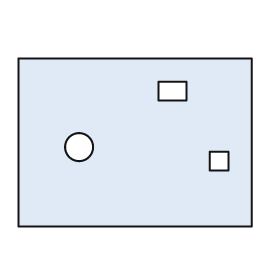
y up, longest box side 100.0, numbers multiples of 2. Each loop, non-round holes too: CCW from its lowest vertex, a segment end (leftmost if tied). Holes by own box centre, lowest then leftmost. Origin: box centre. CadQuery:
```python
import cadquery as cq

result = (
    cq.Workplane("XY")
    .moveTo(-50.0, -36.0)
    .lineTo(50.0, -36.0)
    .lineTo(50.0, 36.0)
    .lineTo(-50.0, 36.0)
    .close()
    .moveTo(32.0, -12.0)
    .lineTo(40.0, -12.0)
    .lineTo(40.0, -4.0)
    .lineTo(32.0, -4.0)
    .close()
    .moveTo(-24.0, -2.0)
    .circle(6.0)
    .moveTo(10.0, 18.0)
    .lineTo(22.0, 18.0)
    .lineTo(22.0, 26.0)
    .lineTo(10.0, 26.0)
    .close()
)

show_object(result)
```